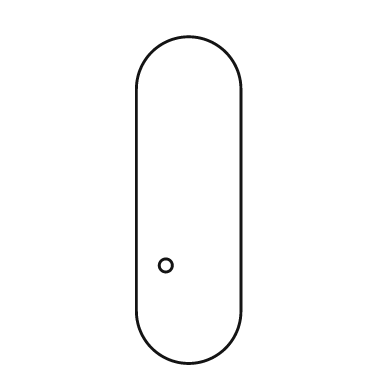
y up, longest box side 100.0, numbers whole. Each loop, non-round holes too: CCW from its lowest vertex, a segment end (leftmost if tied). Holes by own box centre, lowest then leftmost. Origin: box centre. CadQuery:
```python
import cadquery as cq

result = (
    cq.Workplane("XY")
    .moveTo(-16.0, -34.0)
    .threePointArc((0.0, -50.0), (16.0, -34.0))
    .lineTo(16.0, 34.0)
    .threePointArc((0.0, 50.0), (-16.0, 34.0))
    .close()
    .moveTo(-7.0, -20.0)
    .circle(2.0)
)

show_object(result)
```